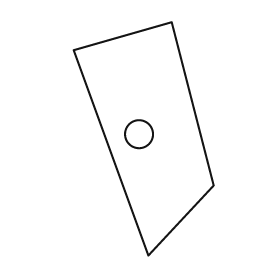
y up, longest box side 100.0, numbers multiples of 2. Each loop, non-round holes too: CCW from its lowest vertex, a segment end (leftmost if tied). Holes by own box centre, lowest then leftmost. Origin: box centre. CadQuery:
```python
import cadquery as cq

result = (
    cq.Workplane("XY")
    .moveTo(2.0, -50.0)
    .lineTo(30.0, -20.0)
    .lineTo(12.0, 50.0)
    .lineTo(-30.0, 38.0)
    .close()
    .moveTo(-2.0, 2.0)
    .circle(6.0)
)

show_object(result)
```